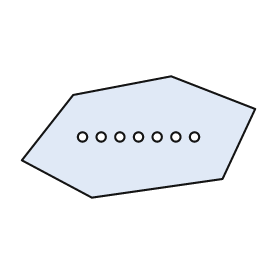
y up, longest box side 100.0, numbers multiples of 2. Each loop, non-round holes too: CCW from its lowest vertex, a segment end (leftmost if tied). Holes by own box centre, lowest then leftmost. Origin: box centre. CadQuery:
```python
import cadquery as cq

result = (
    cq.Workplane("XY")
    .moveTo(-20.0, -26.0)
    .lineTo(36.0, -18.0)
    .lineTo(50.0, 12.0)
    .lineTo(14.0, 26.0)
    .lineTo(-28.0, 18.0)
    .lineTo(-50.0, -10.0)
    .close()
    .moveTo(-24.0, 0.0)
    .circle(2.0)
    .moveTo(-16.0, 0.0)
    .circle(2.0)
    .moveTo(-8.0, 0.0)
    .circle(2.0)
    .moveTo(0.0, 0.0)
    .circle(2.0)
    .moveTo(8.0, 0.0)
    .circle(2.0)
    .moveTo(16.0, 0.0)
    .circle(2.0)
    .moveTo(24.0, 0.0)
    .circle(2.0)
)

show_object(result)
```